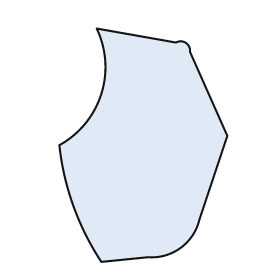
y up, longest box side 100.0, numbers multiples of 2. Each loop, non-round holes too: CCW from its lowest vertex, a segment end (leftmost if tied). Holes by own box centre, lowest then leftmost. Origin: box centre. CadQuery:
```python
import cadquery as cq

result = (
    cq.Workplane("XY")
    .moveTo(-18.0, -50.0)
    .lineTo(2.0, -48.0)
    .threePointArc((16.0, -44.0), (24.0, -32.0))
    .lineTo(36.0, 4.0)
    .lineTo(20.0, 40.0)
    .threePointArc((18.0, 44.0), (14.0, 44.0))
    .lineTo(-20.0, 50.0)
    .threePointArc((-18.0, 22.0), (-36.0, 0.0))
    .threePointArc((-30.0, -26.0), (-18.0, -50.0))
    .close()
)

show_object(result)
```